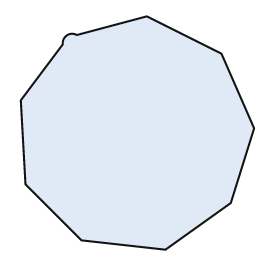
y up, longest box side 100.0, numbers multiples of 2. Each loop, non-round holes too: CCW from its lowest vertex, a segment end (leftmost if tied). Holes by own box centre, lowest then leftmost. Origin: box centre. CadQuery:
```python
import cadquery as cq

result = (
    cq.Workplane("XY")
    .moveTo(12.0, -50.0)
    .lineTo(40.0, -30.0)
    .lineTo(50.0, 2.0)
    .lineTo(36.0, 34.0)
    .lineTo(4.0, 50.0)
    .lineTo(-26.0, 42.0)
    .threePointArc((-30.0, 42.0), (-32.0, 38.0))
    .lineTo(-50.0, 14.0)
    .lineTo(-48.0, -22.0)
    .lineTo(-24.0, -46.0)
    .close()
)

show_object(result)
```